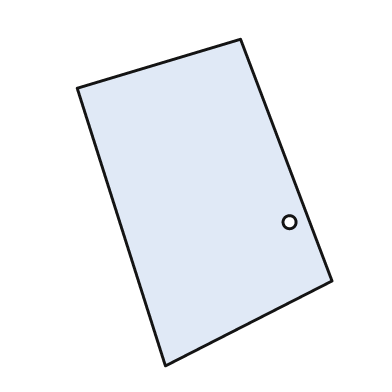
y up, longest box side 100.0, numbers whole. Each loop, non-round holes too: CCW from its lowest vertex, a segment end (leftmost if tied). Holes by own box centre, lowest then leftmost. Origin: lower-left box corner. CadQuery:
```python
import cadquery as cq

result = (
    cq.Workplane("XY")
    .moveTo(27.0, 0.0)
    .lineTo(78.0, 26.0)
    .lineTo(50.0, 100.0)
    .lineTo(0.0, 85.0)
    .close()
    .moveTo(65.0, 44.0)
    .circle(2.0)
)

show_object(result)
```